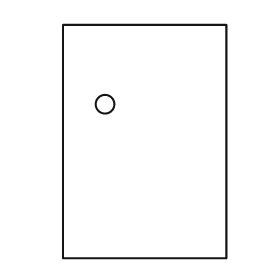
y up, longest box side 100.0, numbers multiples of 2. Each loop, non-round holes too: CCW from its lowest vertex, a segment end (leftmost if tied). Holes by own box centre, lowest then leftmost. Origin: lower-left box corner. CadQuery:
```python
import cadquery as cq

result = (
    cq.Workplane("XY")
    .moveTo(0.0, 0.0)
    .lineTo(70.0, 0.0)
    .lineTo(70.0, 100.0)
    .lineTo(0.0, 100.0)
    .close()
    .moveTo(18.0, 66.0)
    .circle(4.0)
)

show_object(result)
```